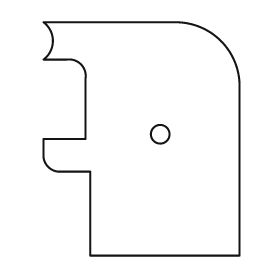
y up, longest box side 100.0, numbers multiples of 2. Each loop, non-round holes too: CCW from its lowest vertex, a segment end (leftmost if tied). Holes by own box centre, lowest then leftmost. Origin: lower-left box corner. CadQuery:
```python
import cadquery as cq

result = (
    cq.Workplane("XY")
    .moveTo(20.0, 0.0)
    .lineTo(84.0, 0.0)
    .lineTo(84.0, 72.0)
    .threePointArc((76.0, 92.0), (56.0, 100.0))
    .lineTo(0.0, 100.0)
    .threePointArc((4.0, 92.0), (0.0, 84.0))
    .lineTo(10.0, 84.0)
    .threePointArc((16.0, 82.0), (18.0, 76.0))
    .lineTo(18.0, 50.0)
    .lineTo(0.0, 50.0)
    .lineTo(0.0, 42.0)
    .threePointArc((2.0, 38.0), (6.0, 36.0))
    .lineTo(20.0, 36.0)
    .close()
    .moveTo(50.0, 52.0)
    .circle(4.0)
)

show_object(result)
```